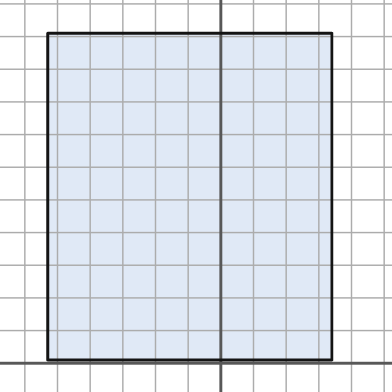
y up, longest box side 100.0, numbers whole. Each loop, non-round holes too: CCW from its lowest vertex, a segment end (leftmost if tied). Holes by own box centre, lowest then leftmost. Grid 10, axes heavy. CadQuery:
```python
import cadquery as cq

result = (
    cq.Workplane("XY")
    .moveTo(-53.0, 1.0)
    .lineTo(34.0, 1.0)
    .lineTo(34.0, 101.0)
    .lineTo(-53.0, 101.0)
    .close()
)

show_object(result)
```